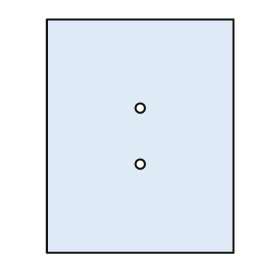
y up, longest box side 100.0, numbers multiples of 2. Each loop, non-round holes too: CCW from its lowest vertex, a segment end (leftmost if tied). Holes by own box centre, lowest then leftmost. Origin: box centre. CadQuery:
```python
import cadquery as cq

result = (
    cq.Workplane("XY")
    .moveTo(-40.0, -50.0)
    .lineTo(40.0, -50.0)
    .lineTo(40.0, 50.0)
    .lineTo(-40.0, 50.0)
    .close()
    .moveTo(0.0, -12.0)
    .circle(2.0)
    .moveTo(0.0, 12.0)
    .circle(2.0)
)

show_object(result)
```